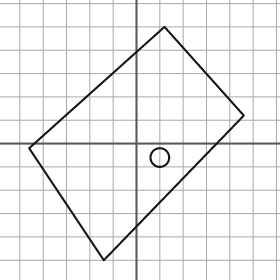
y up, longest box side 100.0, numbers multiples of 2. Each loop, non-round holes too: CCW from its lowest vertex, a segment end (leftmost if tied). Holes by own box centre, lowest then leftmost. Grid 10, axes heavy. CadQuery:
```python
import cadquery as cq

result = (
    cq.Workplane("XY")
    .moveTo(-14.0, -50.0)
    .lineTo(46.0, 12.0)
    .lineTo(12.0, 50.0)
    .lineTo(-46.0, -2.0)
    .close()
    .moveTo(10.0, -6.0)
    .circle(4.0)
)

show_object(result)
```